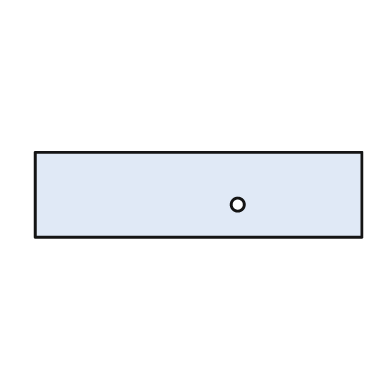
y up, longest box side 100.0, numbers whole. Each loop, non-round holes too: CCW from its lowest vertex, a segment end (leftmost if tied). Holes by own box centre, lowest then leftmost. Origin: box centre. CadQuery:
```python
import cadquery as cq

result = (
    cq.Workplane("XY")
    .moveTo(-50.0, -13.0)
    .lineTo(50.0, -13.0)
    .lineTo(50.0, 13.0)
    .lineTo(-50.0, 13.0)
    .close()
    .moveTo(12.0, -3.0)
    .circle(2.0)
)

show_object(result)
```